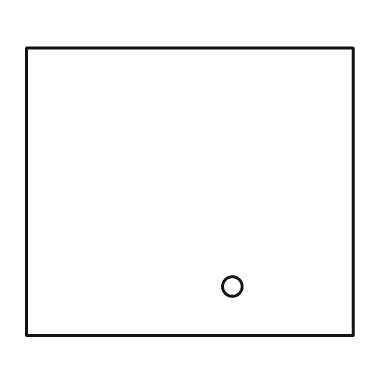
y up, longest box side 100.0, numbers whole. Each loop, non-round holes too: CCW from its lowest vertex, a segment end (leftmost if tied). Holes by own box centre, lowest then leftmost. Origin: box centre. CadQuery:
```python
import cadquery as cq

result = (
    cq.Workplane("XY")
    .moveTo(-50.0, -44.0)
    .lineTo(50.0, -44.0)
    .lineTo(50.0, 44.0)
    .lineTo(-50.0, 44.0)
    .close()
    .moveTo(13.0, -29.0)
    .circle(3.0)
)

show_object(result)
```